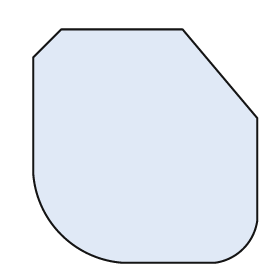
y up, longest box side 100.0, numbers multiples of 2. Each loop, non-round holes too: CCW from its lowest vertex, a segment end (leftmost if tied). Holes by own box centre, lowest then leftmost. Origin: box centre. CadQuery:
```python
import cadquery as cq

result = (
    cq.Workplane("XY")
    .moveTo(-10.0, -50.0)
    .lineTo(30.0, -50.0)
    .threePointArc((42.0, -44.0), (48.0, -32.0))
    .lineTo(48.0, 12.0)
    .lineTo(16.0, 50.0)
    .lineTo(-36.0, 50.0)
    .lineTo(-48.0, 38.0)
    .lineTo(-48.0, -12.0)
    .threePointArc((-36.0, -38.0), (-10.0, -50.0))
    .close()
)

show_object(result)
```